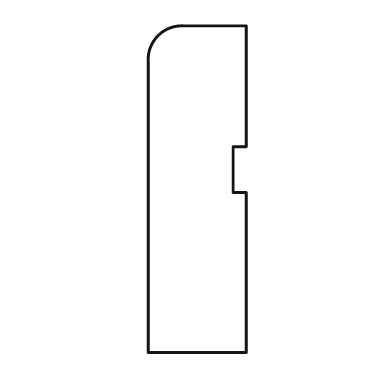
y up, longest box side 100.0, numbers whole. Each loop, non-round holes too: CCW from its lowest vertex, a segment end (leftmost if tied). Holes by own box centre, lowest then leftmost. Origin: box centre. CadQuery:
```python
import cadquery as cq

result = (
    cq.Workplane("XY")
    .moveTo(-15.0, -50.0)
    .lineTo(15.0, -50.0)
    .lineTo(15.0, -1.0)
    .lineTo(11.0, -1.0)
    .lineTo(11.0, 13.0)
    .lineTo(15.0, 13.0)
    .lineTo(15.0, 50.0)
    .lineTo(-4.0, 50.0)
    .threePointArc((-12.0, 47.0), (-15.0, 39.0))
    .close()
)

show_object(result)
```